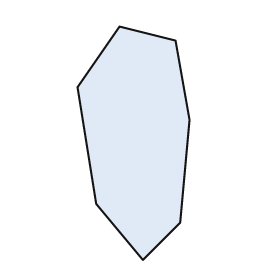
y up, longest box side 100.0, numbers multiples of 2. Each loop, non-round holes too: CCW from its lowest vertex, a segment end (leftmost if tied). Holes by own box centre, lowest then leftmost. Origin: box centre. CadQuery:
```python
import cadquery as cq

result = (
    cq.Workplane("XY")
    .moveTo(4.0, -50.0)
    .lineTo(20.0, -34.0)
    .lineTo(24.0, 10.0)
    .lineTo(18.0, 44.0)
    .lineTo(-6.0, 50.0)
    .lineTo(-24.0, 24.0)
    .lineTo(-16.0, -26.0)
    .close()
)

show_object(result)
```